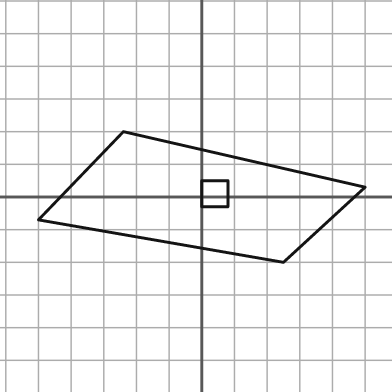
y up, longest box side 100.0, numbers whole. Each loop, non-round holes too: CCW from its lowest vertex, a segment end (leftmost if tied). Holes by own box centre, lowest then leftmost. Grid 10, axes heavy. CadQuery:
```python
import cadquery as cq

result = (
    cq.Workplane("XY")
    .moveTo(25.0, -20.0)
    .lineTo(50.0, 3.0)
    .lineTo(-24.0, 20.0)
    .lineTo(-50.0, -7.0)
    .close()
    .moveTo(0.0, -3.0)
    .lineTo(8.0, -3.0)
    .lineTo(8.0, 5.0)
    .lineTo(0.0, 5.0)
    .close()
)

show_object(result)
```